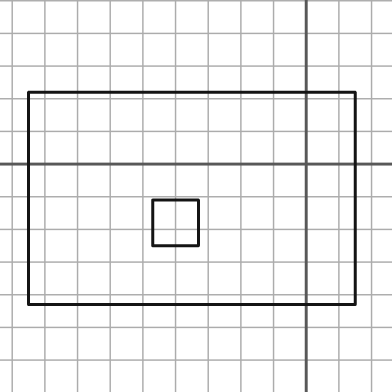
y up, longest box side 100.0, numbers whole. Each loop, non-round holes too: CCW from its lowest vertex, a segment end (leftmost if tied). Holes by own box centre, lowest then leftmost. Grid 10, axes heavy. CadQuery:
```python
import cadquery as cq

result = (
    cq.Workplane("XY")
    .moveTo(-85.0, -43.0)
    .lineTo(15.0, -43.0)
    .lineTo(15.0, 22.0)
    .lineTo(-85.0, 22.0)
    .close()
    .moveTo(-47.0, -25.0)
    .lineTo(-33.0, -25.0)
    .lineTo(-33.0, -11.0)
    .lineTo(-47.0, -11.0)
    .close()
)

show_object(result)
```